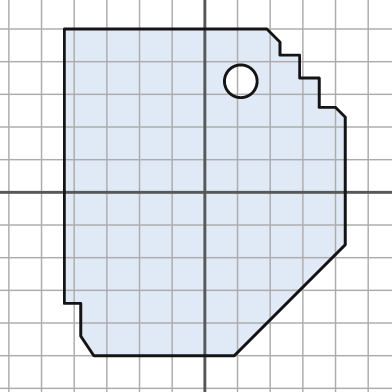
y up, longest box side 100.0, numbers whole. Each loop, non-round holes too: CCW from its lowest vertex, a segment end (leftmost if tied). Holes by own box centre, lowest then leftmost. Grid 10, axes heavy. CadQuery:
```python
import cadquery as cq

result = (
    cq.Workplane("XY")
    .moveTo(-34.0, -50.0)
    .lineTo(9.0, -50.0)
    .lineTo(43.0, -16.0)
    .lineTo(43.0, 23.0)
    .lineTo(40.0, 26.0)
    .lineTo(35.0, 26.0)
    .lineTo(35.0, 35.0)
    .lineTo(29.0, 35.0)
    .lineTo(29.0, 42.0)
    .lineTo(23.0, 42.0)
    .lineTo(23.0, 46.0)
    .lineTo(19.0, 50.0)
    .lineTo(-43.0, 50.0)
    .lineTo(-43.0, -34.0)
    .lineTo(-38.0, -34.0)
    .lineTo(-38.0, -44.0)
    .close()
    .moveTo(11.0, 34.0)
    .circle(5.0)
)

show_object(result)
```